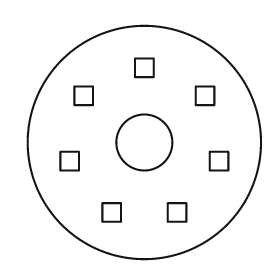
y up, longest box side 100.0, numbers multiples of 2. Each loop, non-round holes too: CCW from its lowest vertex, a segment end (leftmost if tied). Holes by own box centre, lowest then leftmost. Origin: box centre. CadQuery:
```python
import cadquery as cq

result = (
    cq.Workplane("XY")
    .moveTo(0.0, 0.0)
    .circle(50.0)
    .moveTo(-18.0, -34.0)
    .lineTo(-10.0, -34.0)
    .lineTo(-10.0, -26.0)
    .lineTo(-18.0, -26.0)
    .close()
    .moveTo(10.0, -34.0)
    .lineTo(18.0, -34.0)
    .lineTo(18.0, -26.0)
    .lineTo(10.0, -26.0)
    .close()
    .moveTo(-36.0, -12.0)
    .lineTo(-28.0, -12.0)
    .lineTo(-28.0, -4.0)
    .lineTo(-36.0, -4.0)
    .close()
    .moveTo(28.0, -12.0)
    .lineTo(36.0, -12.0)
    .lineTo(36.0, -4.0)
    .lineTo(28.0, -4.0)
    .close()
    .moveTo(0.0, 0.0)
    .circle(12.0)
    .moveTo(-30.0, 16.0)
    .lineTo(-22.0, 16.0)
    .lineTo(-22.0, 24.0)
    .lineTo(-30.0, 24.0)
    .close()
    .moveTo(22.0, 16.0)
    .lineTo(30.0, 16.0)
    .lineTo(30.0, 24.0)
    .lineTo(22.0, 24.0)
    .close()
    .moveTo(-4.0, 28.0)
    .lineTo(4.0, 28.0)
    .lineTo(4.0, 36.0)
    .lineTo(-4.0, 36.0)
    .close()
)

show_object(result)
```